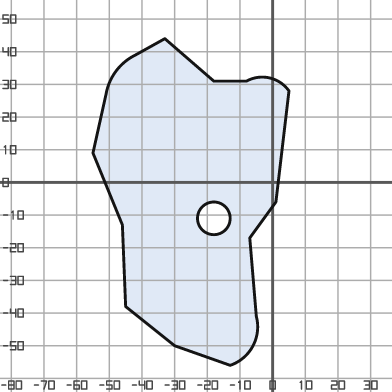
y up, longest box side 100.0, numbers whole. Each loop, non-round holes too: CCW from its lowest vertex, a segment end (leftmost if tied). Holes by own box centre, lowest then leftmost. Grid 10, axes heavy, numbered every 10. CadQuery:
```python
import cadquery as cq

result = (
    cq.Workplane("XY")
    .moveTo(-13.0, -56.0)
    .threePointArc((-6.0, -50.0), (-5.0, -41.0))
    .lineTo(-7.0, -17.0)
    .lineTo(1.0, -6.0)
    .lineTo(5.0, 28.0)
    .threePointArc((-1.0, 32.0), (-8.0, 31.0))
    .lineTo(-18.0, 31.0)
    .lineTo(-33.0, 44.0)
    .lineTo(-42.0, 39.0)
    .threePointArc((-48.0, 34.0), (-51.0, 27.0))
    .lineTo(-55.0, 9.0)
    .lineTo(-46.0, -13.0)
    .lineTo(-45.0, -38.0)
    .lineTo(-30.0, -50.0)
    .close()
    .moveTo(-18.0, -11.0)
    .circle(5.0)
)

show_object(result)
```